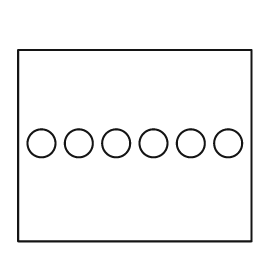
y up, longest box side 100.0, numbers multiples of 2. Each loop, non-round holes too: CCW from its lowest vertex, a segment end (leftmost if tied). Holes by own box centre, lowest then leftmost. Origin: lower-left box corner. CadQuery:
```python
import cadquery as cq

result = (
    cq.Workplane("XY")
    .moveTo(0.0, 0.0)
    .lineTo(100.0, 0.0)
    .lineTo(100.0, 82.0)
    .lineTo(0.0, 82.0)
    .close()
    .moveTo(10.0, 42.0)
    .circle(6.0)
    .moveTo(26.0, 42.0)
    .circle(6.0)
    .moveTo(42.0, 42.0)
    .circle(6.0)
    .moveTo(58.0, 42.0)
    .circle(6.0)
    .moveTo(74.0, 42.0)
    .circle(6.0)
    .moveTo(90.0, 42.0)
    .circle(6.0)
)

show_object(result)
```